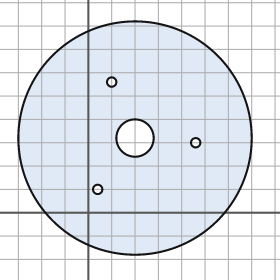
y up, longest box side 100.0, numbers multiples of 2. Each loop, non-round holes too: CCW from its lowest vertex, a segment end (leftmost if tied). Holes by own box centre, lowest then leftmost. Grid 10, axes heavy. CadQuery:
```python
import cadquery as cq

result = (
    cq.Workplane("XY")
    .moveTo(20.0, 32.0)
    .circle(50.0)
    .moveTo(4.0, 10.0)
    .circle(2.0)
    .moveTo(46.0, 30.0)
    .circle(2.0)
    .moveTo(20.0, 32.0)
    .circle(8.0)
    .moveTo(10.0, 56.0)
    .circle(2.0)
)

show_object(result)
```